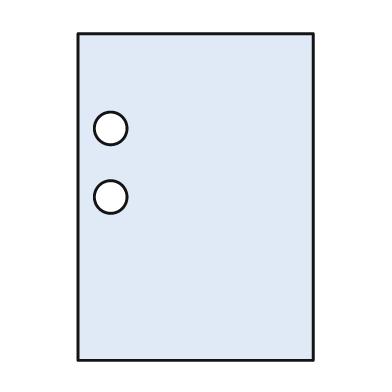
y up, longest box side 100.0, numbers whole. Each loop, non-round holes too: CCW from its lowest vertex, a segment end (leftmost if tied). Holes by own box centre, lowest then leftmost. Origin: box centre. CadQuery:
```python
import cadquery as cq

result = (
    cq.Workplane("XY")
    .moveTo(-36.0, -50.0)
    .lineTo(36.0, -50.0)
    .lineTo(36.0, 50.0)
    .lineTo(-36.0, 50.0)
    .close()
    .moveTo(-26.0, 0.0)
    .circle(5.0)
    .moveTo(-26.0, 21.0)
    .circle(5.0)
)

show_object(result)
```